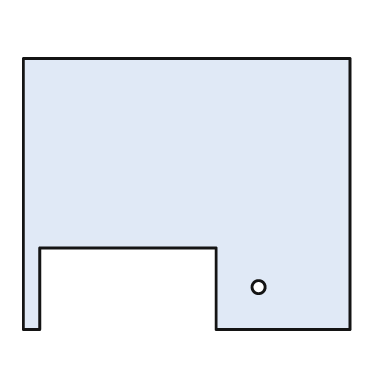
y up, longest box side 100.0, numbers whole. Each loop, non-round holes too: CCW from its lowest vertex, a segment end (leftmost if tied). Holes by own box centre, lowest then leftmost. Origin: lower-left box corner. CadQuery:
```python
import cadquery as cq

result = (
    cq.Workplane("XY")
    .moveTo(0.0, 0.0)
    .lineTo(5.0, 0.0)
    .lineTo(5.0, 25.0)
    .lineTo(59.0, 25.0)
    .lineTo(59.0, 0.0)
    .lineTo(100.0, 0.0)
    .lineTo(100.0, 83.0)
    .lineTo(0.0, 83.0)
    .close()
    .moveTo(72.0, 13.0)
    .circle(2.0)
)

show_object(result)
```